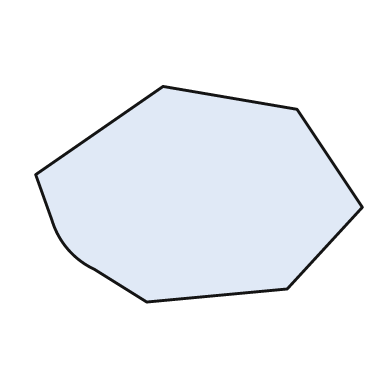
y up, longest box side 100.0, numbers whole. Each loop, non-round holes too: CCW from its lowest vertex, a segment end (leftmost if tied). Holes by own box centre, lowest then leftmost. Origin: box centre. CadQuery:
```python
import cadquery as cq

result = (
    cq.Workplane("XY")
    .moveTo(-16.0, -33.0)
    .lineTo(27.0, -29.0)
    .lineTo(50.0, -4.0)
    .lineTo(30.0, 26.0)
    .lineTo(-11.0, 33.0)
    .lineTo(-50.0, 6.0)
    .lineTo(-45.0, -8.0)
    .threePointArc((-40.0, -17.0), (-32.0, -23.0))
    .close()
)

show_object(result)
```